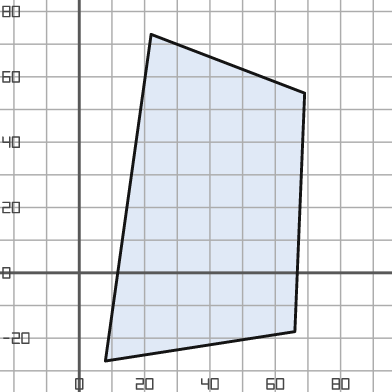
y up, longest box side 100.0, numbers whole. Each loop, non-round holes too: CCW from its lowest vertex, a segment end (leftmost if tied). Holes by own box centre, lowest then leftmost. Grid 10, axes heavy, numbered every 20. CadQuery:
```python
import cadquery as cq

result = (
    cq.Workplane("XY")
    .moveTo(8.0, -27.0)
    .lineTo(66.0, -18.0)
    .lineTo(69.0, 55.0)
    .lineTo(22.0, 73.0)
    .close()
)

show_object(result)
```